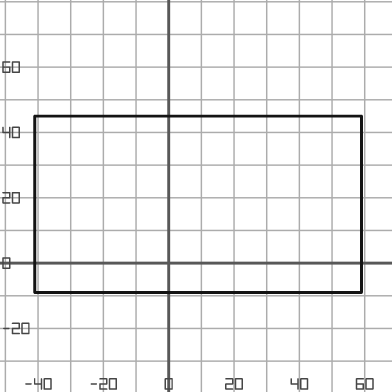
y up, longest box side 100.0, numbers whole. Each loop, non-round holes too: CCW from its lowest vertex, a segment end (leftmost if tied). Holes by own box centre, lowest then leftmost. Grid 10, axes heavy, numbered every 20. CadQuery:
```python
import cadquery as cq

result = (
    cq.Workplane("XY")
    .moveTo(-41.0, -9.0)
    .lineTo(59.0, -9.0)
    .lineTo(59.0, 45.0)
    .lineTo(-41.0, 45.0)
    .close()
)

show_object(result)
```